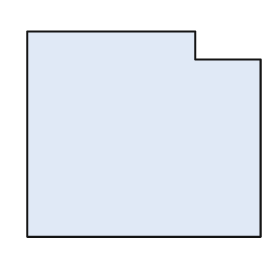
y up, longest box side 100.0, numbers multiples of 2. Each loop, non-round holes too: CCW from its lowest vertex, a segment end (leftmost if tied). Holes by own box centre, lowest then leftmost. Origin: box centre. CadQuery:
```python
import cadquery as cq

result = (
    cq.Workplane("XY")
    .moveTo(-50.0, -44.0)
    .lineTo(50.0, -44.0)
    .lineTo(50.0, 32.0)
    .lineTo(22.0, 32.0)
    .lineTo(22.0, 44.0)
    .lineTo(-50.0, 44.0)
    .close()
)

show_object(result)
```